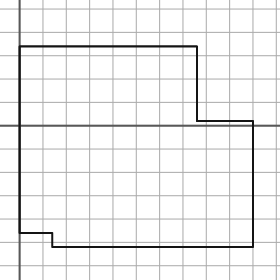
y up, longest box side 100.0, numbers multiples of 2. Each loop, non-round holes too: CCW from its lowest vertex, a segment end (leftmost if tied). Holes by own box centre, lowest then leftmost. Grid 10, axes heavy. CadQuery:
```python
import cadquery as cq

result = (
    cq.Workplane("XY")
    .moveTo(14.0, -52.0)
    .lineTo(100.0, -52.0)
    .lineTo(100.0, 2.0)
    .lineTo(76.0, 2.0)
    .lineTo(76.0, 34.0)
    .lineTo(0.0, 34.0)
    .lineTo(0.0, -46.0)
    .lineTo(14.0, -46.0)
    .close()
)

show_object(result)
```